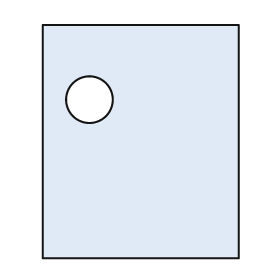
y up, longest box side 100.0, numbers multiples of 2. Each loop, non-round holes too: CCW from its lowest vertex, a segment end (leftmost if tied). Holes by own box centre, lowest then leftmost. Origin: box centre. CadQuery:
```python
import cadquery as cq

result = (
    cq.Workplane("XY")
    .moveTo(-42.0, -50.0)
    .lineTo(42.0, -50.0)
    .lineTo(42.0, 50.0)
    .lineTo(-42.0, 50.0)
    .close()
    .moveTo(-22.0, 18.0)
    .circle(10.0)
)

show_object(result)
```